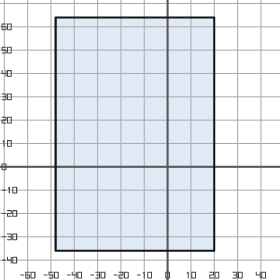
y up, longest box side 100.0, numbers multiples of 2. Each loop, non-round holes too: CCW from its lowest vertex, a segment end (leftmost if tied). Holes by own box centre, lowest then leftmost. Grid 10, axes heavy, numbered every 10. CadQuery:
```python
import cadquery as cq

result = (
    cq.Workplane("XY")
    .moveTo(-48.0, -36.0)
    .lineTo(20.0, -36.0)
    .lineTo(20.0, 64.0)
    .lineTo(-48.0, 64.0)
    .close()
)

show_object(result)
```